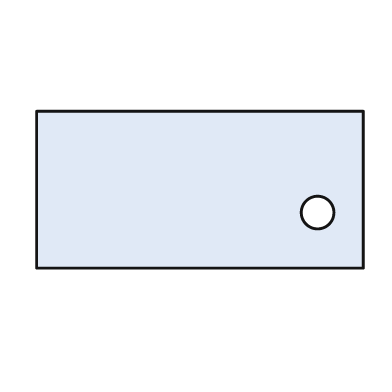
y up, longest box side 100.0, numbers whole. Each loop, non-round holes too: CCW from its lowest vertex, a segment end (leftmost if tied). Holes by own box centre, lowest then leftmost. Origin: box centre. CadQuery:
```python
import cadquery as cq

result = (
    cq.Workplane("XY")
    .moveTo(-50.0, -24.0)
    .lineTo(50.0, -24.0)
    .lineTo(50.0, 24.0)
    .lineTo(-50.0, 24.0)
    .close()
    .moveTo(36.0, -7.0)
    .circle(5.0)
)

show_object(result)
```